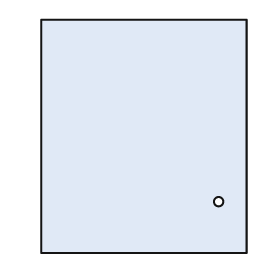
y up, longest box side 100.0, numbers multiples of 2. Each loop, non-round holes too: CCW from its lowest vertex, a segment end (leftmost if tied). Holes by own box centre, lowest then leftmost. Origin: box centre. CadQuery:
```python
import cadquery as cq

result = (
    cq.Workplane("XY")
    .moveTo(-44.0, -50.0)
    .lineTo(44.0, -50.0)
    .lineTo(44.0, 50.0)
    .lineTo(-44.0, 50.0)
    .close()
    .moveTo(32.0, -28.0)
    .circle(2.0)
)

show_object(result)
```